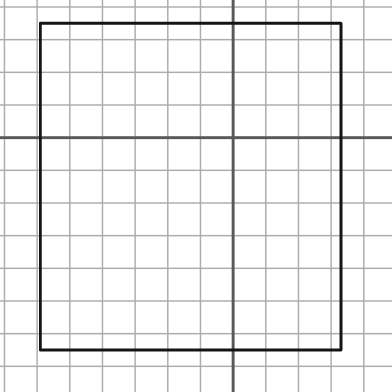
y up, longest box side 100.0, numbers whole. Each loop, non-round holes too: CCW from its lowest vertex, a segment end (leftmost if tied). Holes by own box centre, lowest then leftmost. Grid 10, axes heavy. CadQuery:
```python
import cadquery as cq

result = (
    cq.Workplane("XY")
    .moveTo(-59.0, -65.0)
    .lineTo(33.0, -65.0)
    .lineTo(33.0, 35.0)
    .lineTo(-59.0, 35.0)
    .close()
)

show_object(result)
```